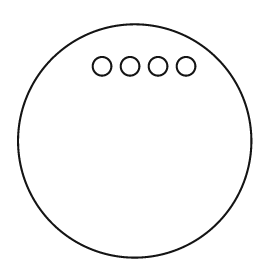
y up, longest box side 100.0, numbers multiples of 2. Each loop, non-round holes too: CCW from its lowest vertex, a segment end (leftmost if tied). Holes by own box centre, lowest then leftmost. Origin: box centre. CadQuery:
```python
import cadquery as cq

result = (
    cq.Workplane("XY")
    .moveTo(0.0, 0.0)
    .circle(50.0)
    .moveTo(-14.0, 32.0)
    .circle(4.0)
    .moveTo(-2.0, 32.0)
    .circle(4.0)
    .moveTo(10.0, 32.0)
    .circle(4.0)
    .moveTo(22.0, 32.0)
    .circle(4.0)
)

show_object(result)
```